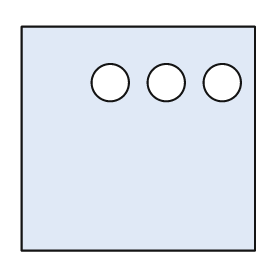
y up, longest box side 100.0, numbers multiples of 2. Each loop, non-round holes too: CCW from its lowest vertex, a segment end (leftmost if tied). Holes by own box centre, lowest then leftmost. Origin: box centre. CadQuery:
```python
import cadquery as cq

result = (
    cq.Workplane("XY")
    .moveTo(-50.0, -48.0)
    .lineTo(50.0, -48.0)
    .lineTo(50.0, 48.0)
    .lineTo(-50.0, 48.0)
    .close()
    .moveTo(-12.0, 24.0)
    .circle(8.0)
    .moveTo(12.0, 24.0)
    .circle(8.0)
    .moveTo(36.0, 24.0)
    .circle(8.0)
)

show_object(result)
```